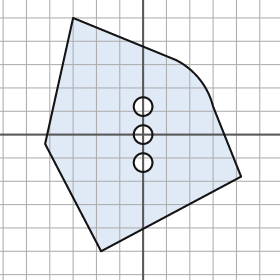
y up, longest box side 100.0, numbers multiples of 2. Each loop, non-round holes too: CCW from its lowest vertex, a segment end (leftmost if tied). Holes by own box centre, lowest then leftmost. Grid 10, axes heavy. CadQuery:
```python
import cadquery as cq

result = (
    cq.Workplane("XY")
    .moveTo(-18.0, -50.0)
    .lineTo(42.0, -18.0)
    .lineTo(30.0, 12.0)
    .threePointArc((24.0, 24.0), (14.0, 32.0))
    .lineTo(-30.0, 50.0)
    .lineTo(-42.0, -4.0)
    .close()
    .moveTo(0.0, -12.0)
    .circle(4.0)
    .moveTo(0.0, 0.0)
    .circle(4.0)
    .moveTo(0.0, 12.0)
    .circle(4.0)
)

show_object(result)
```